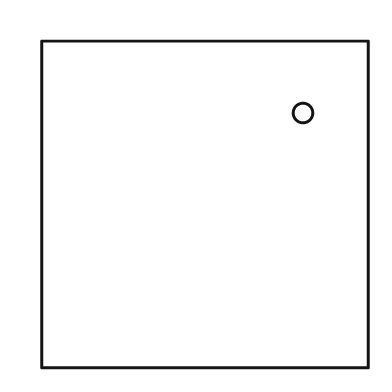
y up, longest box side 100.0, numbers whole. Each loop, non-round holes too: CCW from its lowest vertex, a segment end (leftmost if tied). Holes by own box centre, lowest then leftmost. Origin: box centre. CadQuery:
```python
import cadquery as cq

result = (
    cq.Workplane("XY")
    .moveTo(-50.0, -50.0)
    .lineTo(50.0, -50.0)
    .lineTo(50.0, 50.0)
    .lineTo(-50.0, 50.0)
    .close()
    .moveTo(30.0, 28.0)
    .circle(3.0)
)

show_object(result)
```